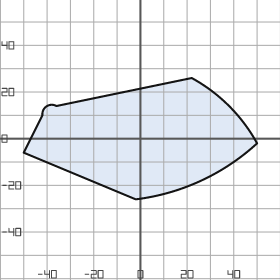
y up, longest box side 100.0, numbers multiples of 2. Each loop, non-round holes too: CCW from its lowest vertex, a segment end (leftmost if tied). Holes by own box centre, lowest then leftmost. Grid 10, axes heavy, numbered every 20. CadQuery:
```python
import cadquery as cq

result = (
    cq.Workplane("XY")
    .moveTo(-2.0, -26.0)
    .threePointArc((26.0, -18.0), (50.0, -2.0))
    .threePointArc((38.0, 14.0), (22.0, 26.0))
    .lineTo(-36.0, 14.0)
    .threePointArc((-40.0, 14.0), (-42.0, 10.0))
    .lineTo(-50.0, -6.0)
    .close()
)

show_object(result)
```